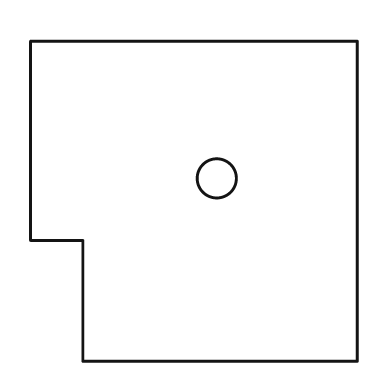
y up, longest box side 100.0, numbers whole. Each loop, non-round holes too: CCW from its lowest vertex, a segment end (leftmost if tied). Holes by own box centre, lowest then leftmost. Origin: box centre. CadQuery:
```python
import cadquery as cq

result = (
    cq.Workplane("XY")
    .moveTo(-34.0, -49.0)
    .lineTo(50.0, -49.0)
    .lineTo(50.0, 49.0)
    .lineTo(-50.0, 49.0)
    .lineTo(-50.0, -12.0)
    .lineTo(-34.0, -12.0)
    .close()
    .moveTo(7.0, 7.0)
    .circle(6.0)
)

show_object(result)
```